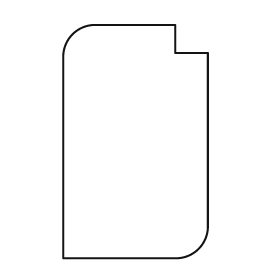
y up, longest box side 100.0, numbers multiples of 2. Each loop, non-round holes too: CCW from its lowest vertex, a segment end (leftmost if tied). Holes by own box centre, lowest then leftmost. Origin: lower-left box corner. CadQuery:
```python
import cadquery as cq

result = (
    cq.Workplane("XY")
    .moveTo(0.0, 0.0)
    .lineTo(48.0, 0.0)
    .threePointArc((58.0, 4.0), (62.0, 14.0))
    .lineTo(62.0, 88.0)
    .lineTo(48.0, 88.0)
    .lineTo(48.0, 100.0)
    .lineTo(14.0, 100.0)
    .threePointArc((4.0, 96.0), (0.0, 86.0))
    .close()
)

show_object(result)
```